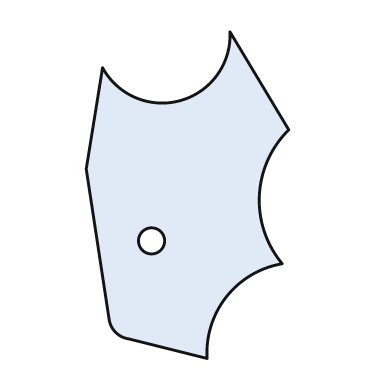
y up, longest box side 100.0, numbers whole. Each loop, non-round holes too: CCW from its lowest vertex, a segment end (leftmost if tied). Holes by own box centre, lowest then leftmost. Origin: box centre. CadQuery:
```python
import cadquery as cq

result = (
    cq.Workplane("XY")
    .moveTo(6.0, -50.0)
    .threePointArc((12.0, -31.0), (29.0, -21.0))
    .threePointArc((22.0, 0.0), (31.0, 20.0))
    .lineTo(13.0, 50.0)
    .threePointArc((-2.0, 29.0), (-26.0, 39.0))
    .lineTo(-31.0, 8.0)
    .lineTo(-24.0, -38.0)
    .threePointArc((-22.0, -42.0), (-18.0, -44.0))
    .close()
    .moveTo(-11.0, -14.0)
    .circle(4.0)
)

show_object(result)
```